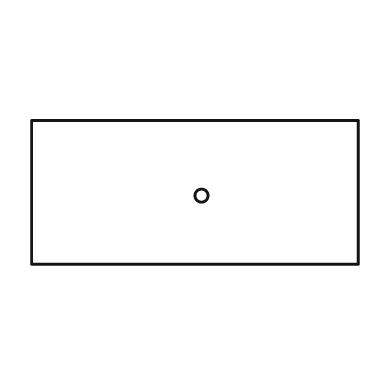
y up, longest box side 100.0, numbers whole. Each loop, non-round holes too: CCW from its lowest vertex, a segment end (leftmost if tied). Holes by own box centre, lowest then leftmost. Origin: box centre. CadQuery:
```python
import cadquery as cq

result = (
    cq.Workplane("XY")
    .moveTo(-50.0, -22.0)
    .lineTo(50.0, -22.0)
    .lineTo(50.0, 22.0)
    .lineTo(-50.0, 22.0)
    .close()
    .moveTo(2.0, -1.0)
    .circle(2.0)
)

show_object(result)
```